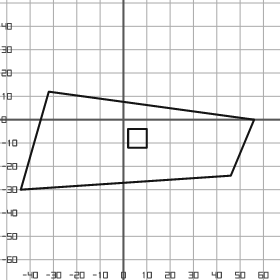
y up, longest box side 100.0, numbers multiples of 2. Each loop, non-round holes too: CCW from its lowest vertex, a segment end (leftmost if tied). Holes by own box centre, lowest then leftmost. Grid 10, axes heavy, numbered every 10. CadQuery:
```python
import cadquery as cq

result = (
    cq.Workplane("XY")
    .moveTo(-44.0, -30.0)
    .lineTo(46.0, -24.0)
    .lineTo(56.0, 0.0)
    .lineTo(-32.0, 12.0)
    .close()
    .moveTo(2.0, -12.0)
    .lineTo(10.0, -12.0)
    .lineTo(10.0, -4.0)
    .lineTo(2.0, -4.0)
    .close()
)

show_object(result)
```